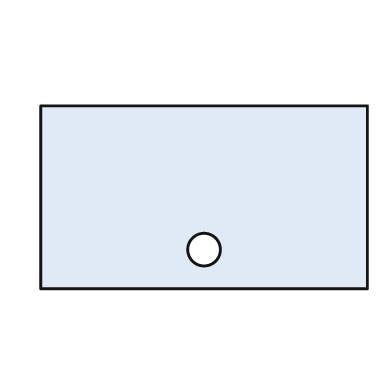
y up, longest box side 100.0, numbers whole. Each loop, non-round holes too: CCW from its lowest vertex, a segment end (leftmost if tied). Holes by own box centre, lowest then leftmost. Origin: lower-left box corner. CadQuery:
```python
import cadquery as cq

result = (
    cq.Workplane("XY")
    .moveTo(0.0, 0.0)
    .lineTo(100.0, 0.0)
    .lineTo(100.0, 56.0)
    .lineTo(0.0, 56.0)
    .close()
    .moveTo(50.0, 12.0)
    .circle(5.0)
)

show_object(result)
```